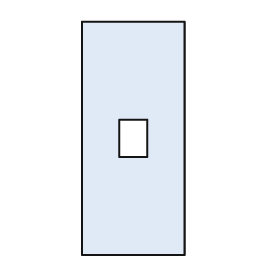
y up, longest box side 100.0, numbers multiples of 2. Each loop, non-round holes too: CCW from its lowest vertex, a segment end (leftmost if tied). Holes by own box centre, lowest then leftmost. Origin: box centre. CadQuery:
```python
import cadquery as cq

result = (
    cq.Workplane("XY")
    .moveTo(-22.0, -50.0)
    .lineTo(22.0, -50.0)
    .lineTo(22.0, 50.0)
    .lineTo(-22.0, 50.0)
    .close()
    .moveTo(-6.0, -8.0)
    .lineTo(6.0, -8.0)
    .lineTo(6.0, 8.0)
    .lineTo(-6.0, 8.0)
    .close()
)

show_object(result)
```